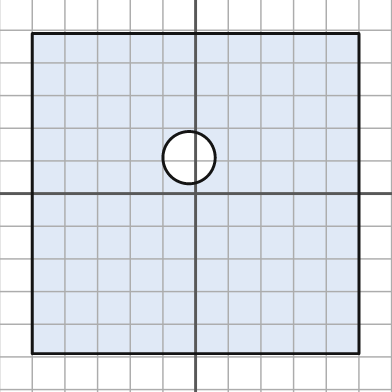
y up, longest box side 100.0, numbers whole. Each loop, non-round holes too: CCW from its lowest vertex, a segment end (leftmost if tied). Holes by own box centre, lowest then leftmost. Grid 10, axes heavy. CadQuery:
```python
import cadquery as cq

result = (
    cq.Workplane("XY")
    .moveTo(-50.0, -49.0)
    .lineTo(50.0, -49.0)
    .lineTo(50.0, 49.0)
    .lineTo(-50.0, 49.0)
    .close()
    .moveTo(-2.0, 11.0)
    .circle(8.0)
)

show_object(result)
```